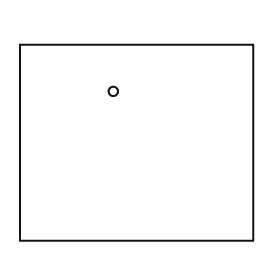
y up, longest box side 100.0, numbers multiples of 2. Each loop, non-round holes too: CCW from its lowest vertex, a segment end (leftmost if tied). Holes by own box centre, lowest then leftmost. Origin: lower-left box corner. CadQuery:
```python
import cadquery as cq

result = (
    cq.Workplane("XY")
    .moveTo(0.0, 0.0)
    .lineTo(100.0, 0.0)
    .lineTo(100.0, 84.0)
    .lineTo(0.0, 84.0)
    .close()
    .moveTo(40.0, 64.0)
    .circle(2.0)
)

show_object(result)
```